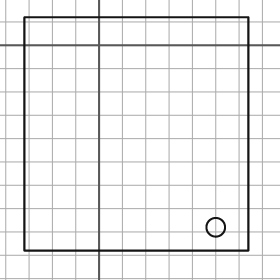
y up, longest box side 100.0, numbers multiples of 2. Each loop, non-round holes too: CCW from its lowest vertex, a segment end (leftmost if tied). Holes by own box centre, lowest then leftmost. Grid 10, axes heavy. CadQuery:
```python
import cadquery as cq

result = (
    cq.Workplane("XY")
    .moveTo(-32.0, -88.0)
    .lineTo(64.0, -88.0)
    .lineTo(64.0, 12.0)
    .lineTo(-32.0, 12.0)
    .close()
    .moveTo(50.0, -78.0)
    .circle(4.0)
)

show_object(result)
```